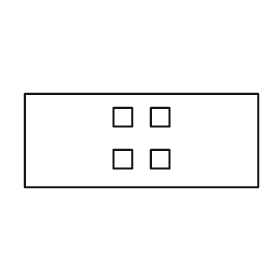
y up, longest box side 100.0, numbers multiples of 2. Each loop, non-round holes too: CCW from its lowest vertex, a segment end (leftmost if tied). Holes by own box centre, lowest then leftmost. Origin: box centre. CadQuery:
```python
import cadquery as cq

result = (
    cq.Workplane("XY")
    .moveTo(-50.0, -20.0)
    .lineTo(50.0, -20.0)
    .lineTo(50.0, 20.0)
    .lineTo(-50.0, 20.0)
    .close()
    .moveTo(-12.0, -12.0)
    .lineTo(-4.0, -12.0)
    .lineTo(-4.0, -4.0)
    .lineTo(-12.0, -4.0)
    .close()
    .moveTo(4.0, -12.0)
    .lineTo(12.0, -12.0)
    .lineTo(12.0, -4.0)
    .lineTo(4.0, -4.0)
    .close()
    .moveTo(-12.0, 6.0)
    .lineTo(-4.0, 6.0)
    .lineTo(-4.0, 14.0)
    .lineTo(-12.0, 14.0)
    .close()
    .moveTo(4.0, 6.0)
    .lineTo(12.0, 6.0)
    .lineTo(12.0, 14.0)
    .lineTo(4.0, 14.0)
    .close()
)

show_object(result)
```